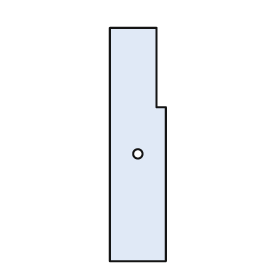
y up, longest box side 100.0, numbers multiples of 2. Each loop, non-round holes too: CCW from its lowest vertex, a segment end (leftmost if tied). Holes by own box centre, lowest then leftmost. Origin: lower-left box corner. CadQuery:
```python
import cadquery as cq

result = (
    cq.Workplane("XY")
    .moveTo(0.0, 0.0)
    .lineTo(24.0, 0.0)
    .lineTo(24.0, 66.0)
    .lineTo(20.0, 66.0)
    .lineTo(20.0, 100.0)
    .lineTo(0.0, 100.0)
    .close()
    .moveTo(12.0, 46.0)
    .circle(2.0)
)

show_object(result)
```